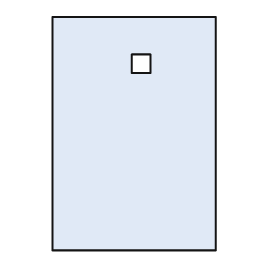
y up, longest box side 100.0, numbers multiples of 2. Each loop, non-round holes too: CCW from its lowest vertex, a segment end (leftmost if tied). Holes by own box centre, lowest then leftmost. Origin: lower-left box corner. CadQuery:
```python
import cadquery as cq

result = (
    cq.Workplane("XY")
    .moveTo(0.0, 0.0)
    .lineTo(70.0, 0.0)
    .lineTo(70.0, 100.0)
    .lineTo(0.0, 100.0)
    .close()
    .moveTo(34.0, 76.0)
    .lineTo(42.0, 76.0)
    .lineTo(42.0, 84.0)
    .lineTo(34.0, 84.0)
    .close()
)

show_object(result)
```